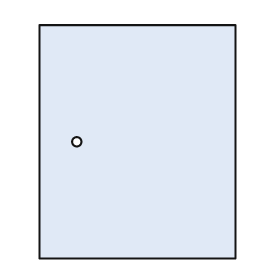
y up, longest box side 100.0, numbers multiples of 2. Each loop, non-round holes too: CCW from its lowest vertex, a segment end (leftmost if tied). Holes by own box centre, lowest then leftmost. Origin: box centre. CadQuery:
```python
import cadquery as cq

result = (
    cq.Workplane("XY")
    .moveTo(-42.0, -50.0)
    .lineTo(42.0, -50.0)
    .lineTo(42.0, 50.0)
    .lineTo(-42.0, 50.0)
    .close()
    .moveTo(-26.0, 0.0)
    .circle(2.0)
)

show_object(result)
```